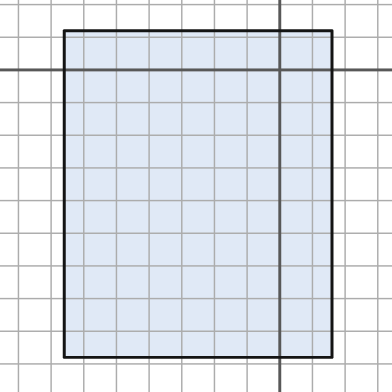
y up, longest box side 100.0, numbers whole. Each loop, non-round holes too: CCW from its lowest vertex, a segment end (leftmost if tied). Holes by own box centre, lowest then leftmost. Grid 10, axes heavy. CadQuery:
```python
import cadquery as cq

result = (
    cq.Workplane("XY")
    .moveTo(-66.0, -88.0)
    .lineTo(16.0, -88.0)
    .lineTo(16.0, 12.0)
    .lineTo(-66.0, 12.0)
    .close()
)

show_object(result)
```